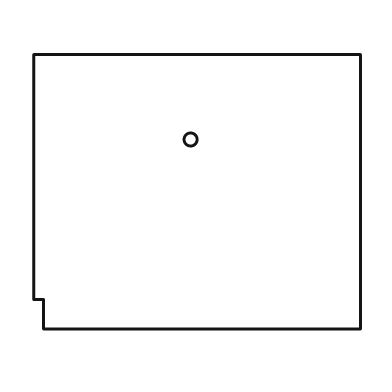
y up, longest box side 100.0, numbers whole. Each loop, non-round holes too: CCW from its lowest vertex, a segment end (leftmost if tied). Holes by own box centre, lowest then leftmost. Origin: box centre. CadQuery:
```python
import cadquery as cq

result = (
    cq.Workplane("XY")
    .moveTo(-47.0, -42.0)
    .lineTo(50.0, -42.0)
    .lineTo(50.0, 42.0)
    .lineTo(-50.0, 42.0)
    .lineTo(-50.0, -33.0)
    .lineTo(-47.0, -33.0)
    .close()
    .moveTo(-2.0, 16.0)
    .circle(2.0)
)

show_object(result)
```